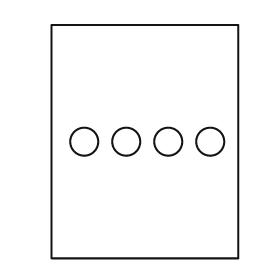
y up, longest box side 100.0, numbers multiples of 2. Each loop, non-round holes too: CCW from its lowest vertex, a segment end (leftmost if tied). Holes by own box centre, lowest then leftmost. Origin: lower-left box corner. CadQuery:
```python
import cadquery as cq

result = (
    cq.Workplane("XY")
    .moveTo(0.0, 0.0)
    .lineTo(80.0, 0.0)
    .lineTo(80.0, 100.0)
    .lineTo(0.0, 100.0)
    .close()
    .moveTo(14.0, 50.0)
    .circle(6.0)
    .moveTo(32.0, 50.0)
    .circle(6.0)
    .moveTo(50.0, 50.0)
    .circle(6.0)
    .moveTo(68.0, 50.0)
    .circle(6.0)
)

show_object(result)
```